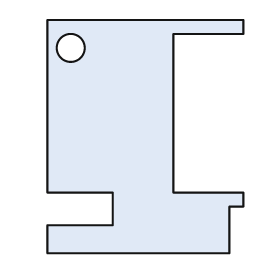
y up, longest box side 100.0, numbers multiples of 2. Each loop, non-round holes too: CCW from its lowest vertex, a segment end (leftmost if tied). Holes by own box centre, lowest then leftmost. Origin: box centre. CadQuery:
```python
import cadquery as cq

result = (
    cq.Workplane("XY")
    .moveTo(-42.0, -50.0)
    .lineTo(36.0, -50.0)
    .lineTo(36.0, -30.0)
    .lineTo(42.0, -30.0)
    .lineTo(42.0, -24.0)
    .lineTo(12.0, -24.0)
    .lineTo(12.0, 44.0)
    .lineTo(42.0, 44.0)
    .lineTo(42.0, 50.0)
    .lineTo(-42.0, 50.0)
    .lineTo(-42.0, -24.0)
    .lineTo(-14.0, -24.0)
    .lineTo(-14.0, -38.0)
    .lineTo(-42.0, -38.0)
    .close()
    .moveTo(-32.0, 38.0)
    .circle(6.0)
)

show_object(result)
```